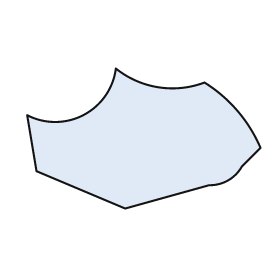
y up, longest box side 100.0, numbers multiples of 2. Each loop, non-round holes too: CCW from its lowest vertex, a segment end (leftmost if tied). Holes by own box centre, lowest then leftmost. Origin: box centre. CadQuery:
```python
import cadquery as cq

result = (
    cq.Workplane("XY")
    .moveTo(-8.0, -30.0)
    .lineTo(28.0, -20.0)
    .threePointArc((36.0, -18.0), (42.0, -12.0))
    .lineTo(50.0, -4.0)
    .threePointArc((40.0, 12.0), (26.0, 24.0))
    .threePointArc((6.0, 22.0), (-12.0, 30.0))
    .threePointArc((-26.0, 10.0), (-50.0, 10.0))
    .lineTo(-46.0, -14.0)
    .close()
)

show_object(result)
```